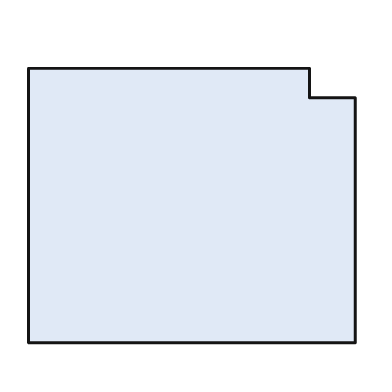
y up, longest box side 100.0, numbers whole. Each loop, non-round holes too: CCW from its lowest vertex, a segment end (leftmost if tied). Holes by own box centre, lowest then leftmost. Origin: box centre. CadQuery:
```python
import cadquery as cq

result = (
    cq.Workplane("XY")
    .moveTo(-50.0, -42.0)
    .lineTo(50.0, -42.0)
    .lineTo(50.0, 33.0)
    .lineTo(36.0, 33.0)
    .lineTo(36.0, 42.0)
    .lineTo(-50.0, 42.0)
    .close()
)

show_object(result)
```